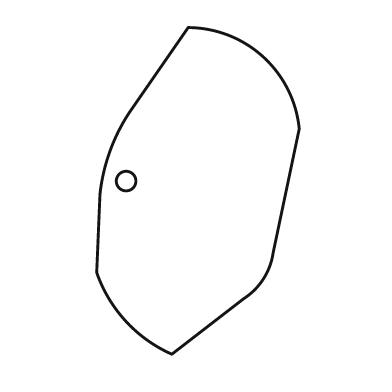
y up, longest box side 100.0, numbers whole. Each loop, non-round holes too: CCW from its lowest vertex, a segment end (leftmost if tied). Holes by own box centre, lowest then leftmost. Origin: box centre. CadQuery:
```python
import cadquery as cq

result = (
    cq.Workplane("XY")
    .moveTo(-8.0, -50.0)
    .lineTo(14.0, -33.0)
    .threePointArc((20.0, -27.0), (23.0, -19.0))
    .lineTo(31.0, 19.0)
    .threePointArc((20.0, 41.0), (-3.0, 50.0))
    .lineTo(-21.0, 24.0)
    .threePointArc((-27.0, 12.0), (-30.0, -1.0))
    .lineTo(-31.0, -25.0)
    .threePointArc((-22.0, -40.0), (-8.0, -50.0))
    .close()
    .moveTo(-22.0, 3.0)
    .circle(3.0)
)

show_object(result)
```